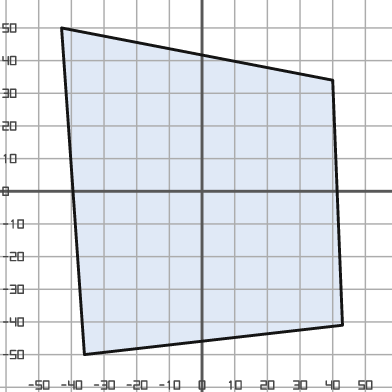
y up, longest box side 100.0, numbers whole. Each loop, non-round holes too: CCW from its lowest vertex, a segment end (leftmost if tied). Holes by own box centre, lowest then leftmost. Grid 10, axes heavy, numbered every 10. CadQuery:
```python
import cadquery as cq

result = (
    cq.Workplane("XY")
    .moveTo(-36.0, -50.0)
    .lineTo(43.0, -41.0)
    .lineTo(40.0, 34.0)
    .lineTo(-43.0, 50.0)
    .close()
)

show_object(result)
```